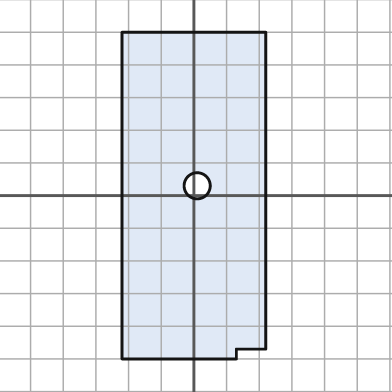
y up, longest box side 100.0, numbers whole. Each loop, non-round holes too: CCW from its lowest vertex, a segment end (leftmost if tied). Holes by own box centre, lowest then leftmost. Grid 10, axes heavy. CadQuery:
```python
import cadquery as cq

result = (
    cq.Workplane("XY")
    .moveTo(-22.0, -50.0)
    .lineTo(13.0, -50.0)
    .lineTo(13.0, -47.0)
    .lineTo(22.0, -47.0)
    .lineTo(22.0, 50.0)
    .lineTo(-22.0, 50.0)
    .close()
    .moveTo(1.0, 3.0)
    .circle(4.0)
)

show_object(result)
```